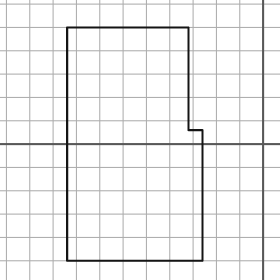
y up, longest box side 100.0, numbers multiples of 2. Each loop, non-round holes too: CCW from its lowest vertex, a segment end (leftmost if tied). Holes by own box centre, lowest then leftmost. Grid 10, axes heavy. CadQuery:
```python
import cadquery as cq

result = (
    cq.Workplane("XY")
    .moveTo(-84.0, -50.0)
    .lineTo(-26.0, -50.0)
    .lineTo(-26.0, 6.0)
    .lineTo(-32.0, 6.0)
    .lineTo(-32.0, 50.0)
    .lineTo(-84.0, 50.0)
    .close()
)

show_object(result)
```